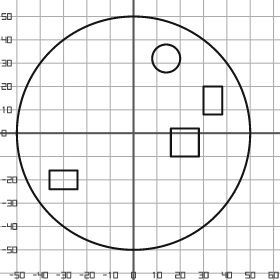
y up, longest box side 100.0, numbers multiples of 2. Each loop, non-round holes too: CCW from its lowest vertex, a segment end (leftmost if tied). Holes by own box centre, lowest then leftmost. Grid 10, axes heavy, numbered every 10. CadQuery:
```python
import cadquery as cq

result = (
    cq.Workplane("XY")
    .moveTo(0.0, 0.0)
    .circle(50.0)
    .moveTo(-36.0, -24.0)
    .lineTo(-24.0, -24.0)
    .lineTo(-24.0, -16.0)
    .lineTo(-36.0, -16.0)
    .close()
    .moveTo(16.0, -10.0)
    .lineTo(28.0, -10.0)
    .lineTo(28.0, 2.0)
    .lineTo(16.0, 2.0)
    .close()
    .moveTo(30.0, 8.0)
    .lineTo(38.0, 8.0)
    .lineTo(38.0, 20.0)
    .lineTo(30.0, 20.0)
    .close()
    .moveTo(14.0, 32.0)
    .circle(6.0)
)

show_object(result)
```